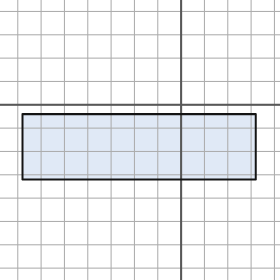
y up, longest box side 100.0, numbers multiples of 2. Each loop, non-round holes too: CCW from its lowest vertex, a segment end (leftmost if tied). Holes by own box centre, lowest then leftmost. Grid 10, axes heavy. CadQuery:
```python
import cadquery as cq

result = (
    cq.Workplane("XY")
    .moveTo(-68.0, -32.0)
    .lineTo(32.0, -32.0)
    .lineTo(32.0, -4.0)
    .lineTo(-68.0, -4.0)
    .close()
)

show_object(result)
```